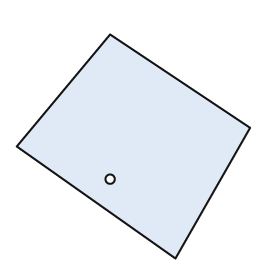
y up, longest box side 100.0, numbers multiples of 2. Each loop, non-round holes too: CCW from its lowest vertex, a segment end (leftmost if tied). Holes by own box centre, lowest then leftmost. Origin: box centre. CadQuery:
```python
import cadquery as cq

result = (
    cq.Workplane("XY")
    .moveTo(18.0, -48.0)
    .lineTo(50.0, 8.0)
    .lineTo(-10.0, 48.0)
    .lineTo(-50.0, 0.0)
    .close()
    .moveTo(-10.0, -14.0)
    .circle(2.0)
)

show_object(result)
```